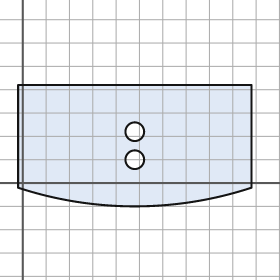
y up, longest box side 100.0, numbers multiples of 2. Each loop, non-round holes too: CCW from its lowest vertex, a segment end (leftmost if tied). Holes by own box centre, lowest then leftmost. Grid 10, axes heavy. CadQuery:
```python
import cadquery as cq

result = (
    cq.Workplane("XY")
    .moveTo(-2.0, -2.0)
    .threePointArc((48.0, -10.0), (98.0, -2.0))
    .lineTo(98.0, 42.0)
    .lineTo(-2.0, 42.0)
    .close()
    .moveTo(48.0, 10.0)
    .circle(4.0)
    .moveTo(48.0, 22.0)
    .circle(4.0)
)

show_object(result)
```